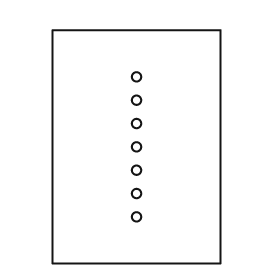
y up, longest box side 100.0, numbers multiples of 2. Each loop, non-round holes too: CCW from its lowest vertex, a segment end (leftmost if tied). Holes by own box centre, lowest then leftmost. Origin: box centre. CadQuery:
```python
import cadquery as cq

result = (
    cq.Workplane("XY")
    .moveTo(-36.0, -50.0)
    .lineTo(36.0, -50.0)
    .lineTo(36.0, 50.0)
    .lineTo(-36.0, 50.0)
    .close()
    .moveTo(0.0, -30.0)
    .circle(2.0)
    .moveTo(0.0, -20.0)
    .circle(2.0)
    .moveTo(0.0, -10.0)
    .circle(2.0)
    .moveTo(0.0, 0.0)
    .circle(2.0)
    .moveTo(0.0, 10.0)
    .circle(2.0)
    .moveTo(0.0, 20.0)
    .circle(2.0)
    .moveTo(0.0, 30.0)
    .circle(2.0)
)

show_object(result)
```